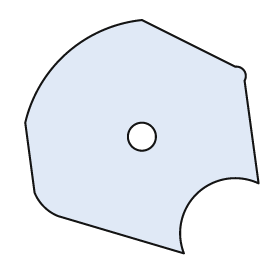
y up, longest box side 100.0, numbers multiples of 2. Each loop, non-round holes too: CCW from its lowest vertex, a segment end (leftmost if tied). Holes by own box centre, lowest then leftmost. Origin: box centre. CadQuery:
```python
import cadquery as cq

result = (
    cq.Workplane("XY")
    .moveTo(18.0, -50.0)
    .threePointArc((24.0, -24.0), (50.0, -20.0))
    .lineTo(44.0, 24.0)
    .threePointArc((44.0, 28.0), (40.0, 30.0))
    .lineTo(0.0, 50.0)
    .threePointArc((-32.0, 36.0), (-50.0, 6.0))
    .lineTo(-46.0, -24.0)
    .threePointArc((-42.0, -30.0), (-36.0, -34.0))
    .close()
    .moveTo(0.0, 0.0)
    .circle(6.0)
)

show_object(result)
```